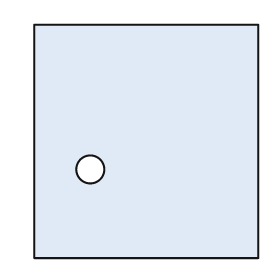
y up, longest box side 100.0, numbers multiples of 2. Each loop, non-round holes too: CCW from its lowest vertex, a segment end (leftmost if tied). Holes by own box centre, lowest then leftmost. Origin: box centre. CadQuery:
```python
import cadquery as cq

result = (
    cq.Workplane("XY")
    .moveTo(-48.0, -50.0)
    .lineTo(48.0, -50.0)
    .lineTo(48.0, 50.0)
    .lineTo(-48.0, 50.0)
    .close()
    .moveTo(-24.0, -12.0)
    .circle(6.0)
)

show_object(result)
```